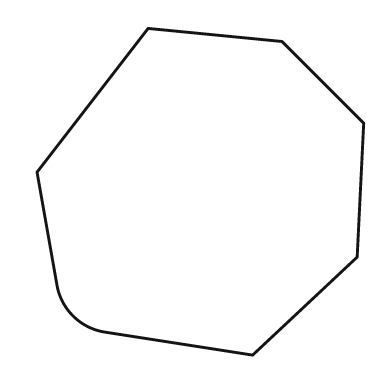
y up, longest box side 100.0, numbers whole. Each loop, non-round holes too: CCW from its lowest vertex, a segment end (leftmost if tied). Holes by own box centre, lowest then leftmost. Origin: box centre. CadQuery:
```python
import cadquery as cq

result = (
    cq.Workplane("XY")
    .moveTo(16.0, -50.0)
    .lineTo(48.0, -20.0)
    .lineTo(50.0, 21.0)
    .lineTo(25.0, 46.0)
    .lineTo(-16.0, 50.0)
    .lineTo(-50.0, 6.0)
    .lineTo(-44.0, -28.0)
    .threePointArc((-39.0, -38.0), (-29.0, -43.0))
    .close()
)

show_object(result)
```